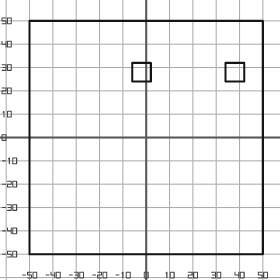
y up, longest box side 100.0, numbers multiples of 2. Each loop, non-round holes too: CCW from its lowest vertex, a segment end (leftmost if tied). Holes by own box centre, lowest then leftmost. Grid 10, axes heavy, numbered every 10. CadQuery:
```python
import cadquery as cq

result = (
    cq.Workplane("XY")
    .moveTo(-50.0, -50.0)
    .lineTo(50.0, -50.0)
    .lineTo(50.0, 50.0)
    .lineTo(-50.0, 50.0)
    .close()
    .moveTo(-6.0, 24.0)
    .lineTo(2.0, 24.0)
    .lineTo(2.0, 32.0)
    .lineTo(-6.0, 32.0)
    .close()
    .moveTo(34.0, 24.0)
    .lineTo(42.0, 24.0)
    .lineTo(42.0, 32.0)
    .lineTo(34.0, 32.0)
    .close()
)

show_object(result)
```